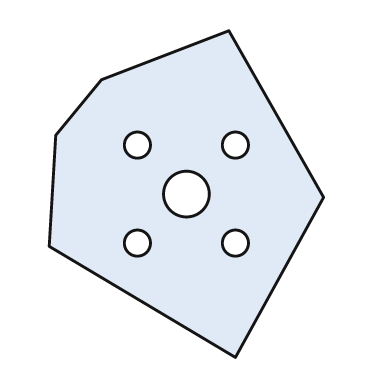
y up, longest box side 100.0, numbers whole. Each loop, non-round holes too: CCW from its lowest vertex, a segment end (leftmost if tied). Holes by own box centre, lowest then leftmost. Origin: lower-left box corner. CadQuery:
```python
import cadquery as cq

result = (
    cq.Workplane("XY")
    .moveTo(57.0, 0.0)
    .lineTo(84.0, 49.0)
    .lineTo(55.0, 100.0)
    .lineTo(16.0, 85.0)
    .lineTo(2.0, 68.0)
    .lineTo(0.0, 34.0)
    .close()
    .moveTo(27.0, 35.0)
    .circle(4.0)
    .moveTo(57.0, 35.0)
    .circle(4.0)
    .moveTo(42.0, 50.0)
    .circle(7.0)
    .moveTo(27.0, 65.0)
    .circle(4.0)
    .moveTo(57.0, 65.0)
    .circle(4.0)
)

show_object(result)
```